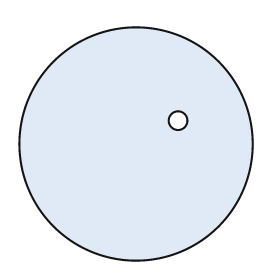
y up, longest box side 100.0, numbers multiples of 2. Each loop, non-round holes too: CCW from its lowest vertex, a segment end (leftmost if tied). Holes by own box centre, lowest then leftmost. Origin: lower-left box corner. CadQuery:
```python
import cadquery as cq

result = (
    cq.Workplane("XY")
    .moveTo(50.0, 50.0)
    .circle(50.0)
    .moveTo(68.0, 60.0)
    .circle(4.0)
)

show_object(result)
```